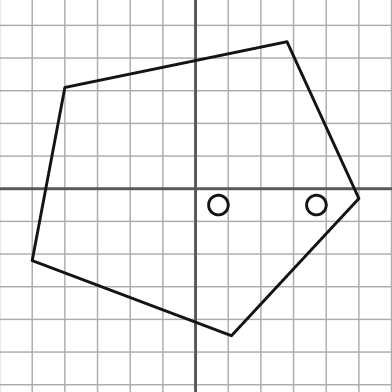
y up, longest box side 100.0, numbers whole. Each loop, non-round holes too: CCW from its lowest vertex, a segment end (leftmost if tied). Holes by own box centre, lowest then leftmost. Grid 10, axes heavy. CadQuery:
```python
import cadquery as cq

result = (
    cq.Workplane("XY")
    .moveTo(11.0, -45.0)
    .lineTo(50.0, -3.0)
    .lineTo(28.0, 45.0)
    .lineTo(-40.0, 31.0)
    .lineTo(-50.0, -22.0)
    .close()
    .moveTo(7.0, -5.0)
    .circle(3.0)
    .moveTo(37.0, -5.0)
    .circle(3.0)
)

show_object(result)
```